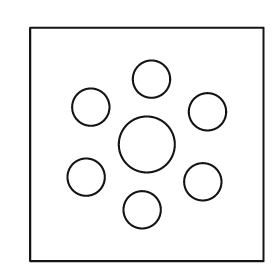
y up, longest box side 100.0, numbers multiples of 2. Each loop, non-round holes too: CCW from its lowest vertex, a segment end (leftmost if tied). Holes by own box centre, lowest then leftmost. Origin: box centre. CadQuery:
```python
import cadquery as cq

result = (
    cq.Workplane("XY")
    .moveTo(-50.0, -50.0)
    .lineTo(50.0, -50.0)
    .lineTo(50.0, 50.0)
    .lineTo(-50.0, 50.0)
    .close()
    .moveTo(-2.0, -28.0)
    .circle(8.0)
    .moveTo(24.0, -16.0)
    .circle(8.0)
    .moveTo(-26.0, -14.0)
    .circle(8.0)
    .moveTo(0.0, 0.0)
    .circle(12.0)
    .moveTo(26.0, 14.0)
    .circle(8.0)
    .moveTo(-24.0, 16.0)
    .circle(8.0)
    .moveTo(2.0, 28.0)
    .circle(8.0)
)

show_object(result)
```